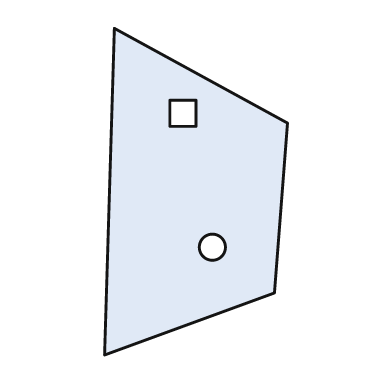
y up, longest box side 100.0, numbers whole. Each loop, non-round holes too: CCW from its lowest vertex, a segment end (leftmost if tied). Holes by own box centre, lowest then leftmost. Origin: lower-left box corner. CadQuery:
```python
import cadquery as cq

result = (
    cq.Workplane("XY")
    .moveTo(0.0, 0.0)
    .lineTo(52.0, 19.0)
    .lineTo(56.0, 71.0)
    .lineTo(3.0, 100.0)
    .close()
    .moveTo(33.0, 33.0)
    .circle(4.0)
    .moveTo(20.0, 70.0)
    .lineTo(28.0, 70.0)
    .lineTo(28.0, 78.0)
    .lineTo(20.0, 78.0)
    .close()
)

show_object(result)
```